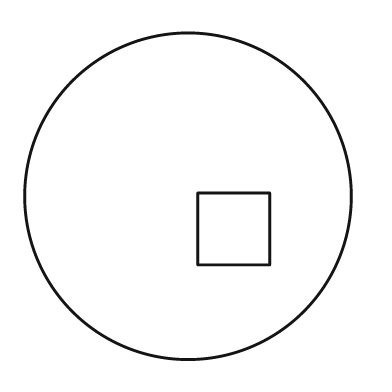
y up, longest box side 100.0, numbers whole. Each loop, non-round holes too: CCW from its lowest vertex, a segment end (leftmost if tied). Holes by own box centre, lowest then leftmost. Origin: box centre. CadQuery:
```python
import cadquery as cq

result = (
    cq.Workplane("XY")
    .moveTo(0.0, 0.0)
    .circle(50.0)
    .moveTo(3.0, -21.0)
    .lineTo(25.0, -21.0)
    .lineTo(25.0, 1.0)
    .lineTo(3.0, 1.0)
    .close()
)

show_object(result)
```